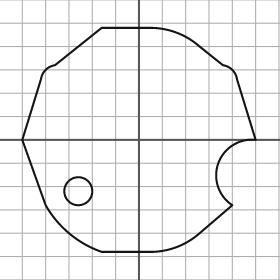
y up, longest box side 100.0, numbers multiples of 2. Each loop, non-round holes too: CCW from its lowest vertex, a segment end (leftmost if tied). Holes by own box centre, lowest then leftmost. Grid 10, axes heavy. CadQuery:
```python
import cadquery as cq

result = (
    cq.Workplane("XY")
    .moveTo(-16.0, -48.0)
    .lineTo(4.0, -48.0)
    .threePointArc((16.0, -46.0), (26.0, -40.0))
    .lineTo(40.0, -28.0)
    .threePointArc((34.0, -10.0), (50.0, 0.0))
    .lineTo(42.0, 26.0)
    .threePointArc((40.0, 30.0), (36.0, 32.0))
    .lineTo(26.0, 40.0)
    .threePointArc((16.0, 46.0), (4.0, 48.0))
    .lineTo(-16.0, 48.0)
    .lineTo(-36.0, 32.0)
    .threePointArc((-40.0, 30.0), (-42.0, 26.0))
    .lineTo(-50.0, 0.0)
    .lineTo(-40.0, -28.0)
    .threePointArc((-30.0, -40.0), (-16.0, -48.0))
    .close()
    .moveTo(-26.0, -22.0)
    .circle(6.0)
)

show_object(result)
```